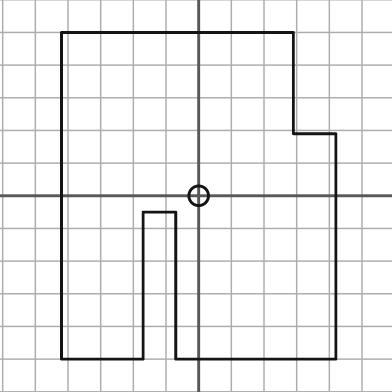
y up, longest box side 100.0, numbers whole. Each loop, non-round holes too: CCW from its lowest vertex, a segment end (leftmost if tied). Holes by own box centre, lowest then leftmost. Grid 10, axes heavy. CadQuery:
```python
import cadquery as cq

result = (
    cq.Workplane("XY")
    .moveTo(-42.0, -50.0)
    .lineTo(-17.0, -50.0)
    .lineTo(-17.0, -5.0)
    .lineTo(-7.0, -5.0)
    .lineTo(-7.0, -50.0)
    .lineTo(42.0, -50.0)
    .lineTo(42.0, 19.0)
    .lineTo(29.0, 19.0)
    .lineTo(29.0, 50.0)
    .lineTo(-42.0, 50.0)
    .close()
    .moveTo(0.0, 0.0)
    .circle(3.0)
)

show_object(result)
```